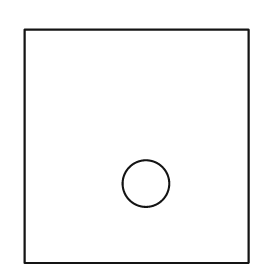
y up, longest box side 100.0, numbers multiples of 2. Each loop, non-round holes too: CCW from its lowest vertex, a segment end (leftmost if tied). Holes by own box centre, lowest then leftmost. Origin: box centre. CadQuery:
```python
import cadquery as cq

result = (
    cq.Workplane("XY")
    .moveTo(-48.0, -50.0)
    .lineTo(48.0, -50.0)
    .lineTo(48.0, 50.0)
    .lineTo(-48.0, 50.0)
    .close()
    .moveTo(4.0, -16.0)
    .circle(10.0)
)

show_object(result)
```